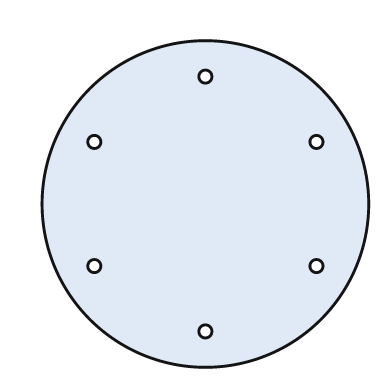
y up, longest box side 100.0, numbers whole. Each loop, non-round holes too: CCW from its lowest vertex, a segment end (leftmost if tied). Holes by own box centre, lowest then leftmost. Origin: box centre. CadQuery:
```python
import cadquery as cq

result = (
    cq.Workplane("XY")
    .moveTo(0.0, 0.0)
    .circle(50.0)
    .moveTo(0.0, -39.0)
    .circle(2.0)
    .moveTo(-34.0, -19.0)
    .circle(2.0)
    .moveTo(34.0, -19.0)
    .circle(2.0)
    .moveTo(-34.0, 19.0)
    .circle(2.0)
    .moveTo(34.0, 19.0)
    .circle(2.0)
    .moveTo(0.0, 39.0)
    .circle(2.0)
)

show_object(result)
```